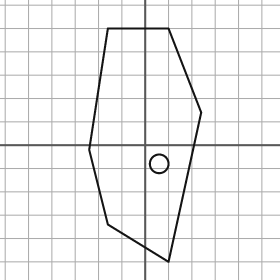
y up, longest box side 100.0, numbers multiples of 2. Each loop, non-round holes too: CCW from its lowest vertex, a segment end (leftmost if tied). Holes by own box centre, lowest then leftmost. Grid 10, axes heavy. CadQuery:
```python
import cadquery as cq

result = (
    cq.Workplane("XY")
    .moveTo(10.0, -50.0)
    .lineTo(24.0, 14.0)
    .lineTo(10.0, 50.0)
    .lineTo(-16.0, 50.0)
    .lineTo(-24.0, -2.0)
    .lineTo(-16.0, -34.0)
    .close()
    .moveTo(6.0, -8.0)
    .circle(4.0)
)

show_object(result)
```